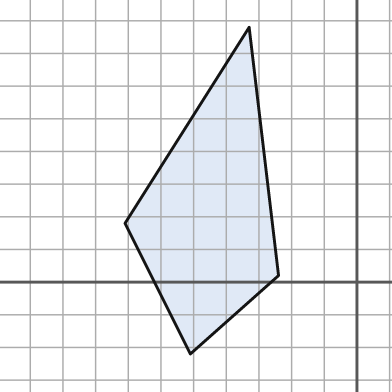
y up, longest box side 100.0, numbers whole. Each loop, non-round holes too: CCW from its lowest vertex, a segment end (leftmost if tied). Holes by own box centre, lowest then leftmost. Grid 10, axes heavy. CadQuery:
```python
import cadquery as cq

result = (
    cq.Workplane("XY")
    .moveTo(-51.0, -22.0)
    .lineTo(-24.0, 2.0)
    .lineTo(-33.0, 78.0)
    .lineTo(-71.0, 18.0)
    .close()
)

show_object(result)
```